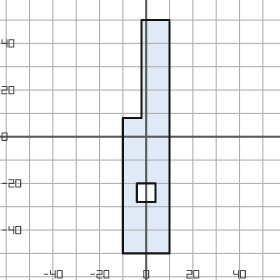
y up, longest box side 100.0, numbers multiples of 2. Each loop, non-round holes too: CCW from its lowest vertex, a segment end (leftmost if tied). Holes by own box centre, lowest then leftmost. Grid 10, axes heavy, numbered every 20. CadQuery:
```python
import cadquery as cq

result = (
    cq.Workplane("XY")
    .moveTo(-10.0, -50.0)
    .lineTo(10.0, -50.0)
    .lineTo(10.0, 50.0)
    .lineTo(-2.0, 50.0)
    .lineTo(-2.0, 8.0)
    .lineTo(-10.0, 8.0)
    .close()
    .moveTo(-4.0, -28.0)
    .lineTo(4.0, -28.0)
    .lineTo(4.0, -20.0)
    .lineTo(-4.0, -20.0)
    .close()
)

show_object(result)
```